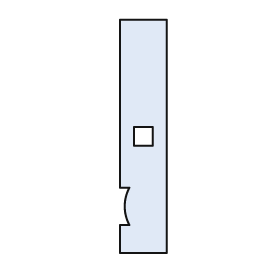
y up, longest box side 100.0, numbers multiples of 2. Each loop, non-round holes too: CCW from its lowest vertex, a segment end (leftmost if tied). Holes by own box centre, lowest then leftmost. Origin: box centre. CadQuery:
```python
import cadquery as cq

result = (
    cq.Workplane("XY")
    .moveTo(-10.0, -50.0)
    .lineTo(10.0, -50.0)
    .lineTo(10.0, 50.0)
    .lineTo(-10.0, 50.0)
    .lineTo(-10.0, -22.0)
    .lineTo(-6.0, -22.0)
    .threePointArc((-8.0, -30.0), (-6.0, -38.0))
    .lineTo(-10.0, -38.0)
    .close()
    .moveTo(-4.0, -4.0)
    .lineTo(4.0, -4.0)
    .lineTo(4.0, 4.0)
    .lineTo(-4.0, 4.0)
    .close()
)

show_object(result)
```